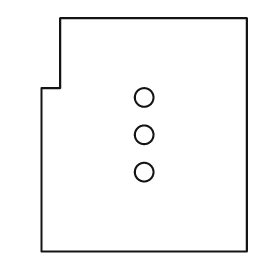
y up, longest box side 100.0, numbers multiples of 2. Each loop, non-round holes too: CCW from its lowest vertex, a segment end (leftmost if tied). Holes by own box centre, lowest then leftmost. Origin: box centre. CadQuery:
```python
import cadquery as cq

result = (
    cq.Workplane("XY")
    .moveTo(-44.0, -50.0)
    .lineTo(44.0, -50.0)
    .lineTo(44.0, 50.0)
    .lineTo(-36.0, 50.0)
    .lineTo(-36.0, 20.0)
    .lineTo(-44.0, 20.0)
    .close()
    .moveTo(0.0, -16.0)
    .circle(4.0)
    .moveTo(0.0, 0.0)
    .circle(4.0)
    .moveTo(0.0, 16.0)
    .circle(4.0)
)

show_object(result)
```